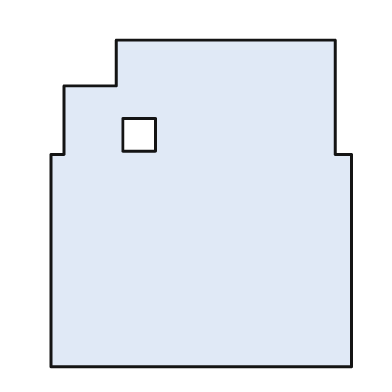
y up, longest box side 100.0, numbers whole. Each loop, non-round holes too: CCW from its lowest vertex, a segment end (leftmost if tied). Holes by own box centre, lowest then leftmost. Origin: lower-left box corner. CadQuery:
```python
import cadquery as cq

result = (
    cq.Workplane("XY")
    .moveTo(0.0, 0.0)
    .lineTo(92.0, 0.0)
    .lineTo(92.0, 65.0)
    .lineTo(87.0, 65.0)
    .lineTo(87.0, 100.0)
    .lineTo(20.0, 100.0)
    .lineTo(20.0, 86.0)
    .lineTo(4.0, 86.0)
    .lineTo(4.0, 65.0)
    .lineTo(0.0, 65.0)
    .close()
    .moveTo(22.0, 66.0)
    .lineTo(32.0, 66.0)
    .lineTo(32.0, 76.0)
    .lineTo(22.0, 76.0)
    .close()
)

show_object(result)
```